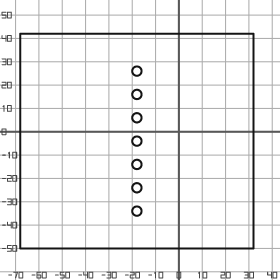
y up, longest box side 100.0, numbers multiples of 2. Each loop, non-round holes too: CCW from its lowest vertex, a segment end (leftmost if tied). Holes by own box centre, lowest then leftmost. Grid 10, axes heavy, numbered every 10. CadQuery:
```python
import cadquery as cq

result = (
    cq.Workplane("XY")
    .moveTo(-68.0, -50.0)
    .lineTo(32.0, -50.0)
    .lineTo(32.0, 42.0)
    .lineTo(-68.0, 42.0)
    .close()
    .moveTo(-18.0, -34.0)
    .circle(2.0)
    .moveTo(-18.0, -24.0)
    .circle(2.0)
    .moveTo(-18.0, -14.0)
    .circle(2.0)
    .moveTo(-18.0, -4.0)
    .circle(2.0)
    .moveTo(-18.0, 6.0)
    .circle(2.0)
    .moveTo(-18.0, 16.0)
    .circle(2.0)
    .moveTo(-18.0, 26.0)
    .circle(2.0)
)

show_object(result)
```